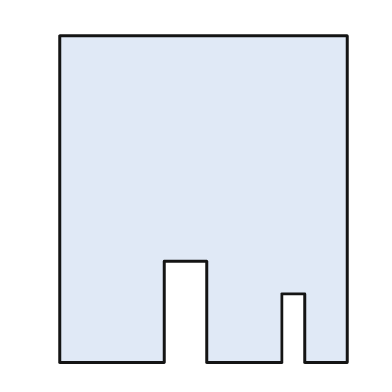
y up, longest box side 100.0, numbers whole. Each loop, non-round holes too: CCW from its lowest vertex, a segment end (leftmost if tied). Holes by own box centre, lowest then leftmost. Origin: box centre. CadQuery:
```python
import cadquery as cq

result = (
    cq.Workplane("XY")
    .moveTo(-44.0, -50.0)
    .lineTo(-12.0, -50.0)
    .lineTo(-12.0, -19.0)
    .lineTo(1.0, -19.0)
    .lineTo(1.0, -50.0)
    .lineTo(24.0, -50.0)
    .lineTo(24.0, -29.0)
    .lineTo(31.0, -29.0)
    .lineTo(31.0, -50.0)
    .lineTo(44.0, -50.0)
    .lineTo(44.0, 50.0)
    .lineTo(-44.0, 50.0)
    .close()
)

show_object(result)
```